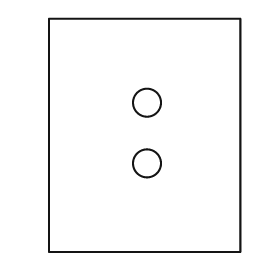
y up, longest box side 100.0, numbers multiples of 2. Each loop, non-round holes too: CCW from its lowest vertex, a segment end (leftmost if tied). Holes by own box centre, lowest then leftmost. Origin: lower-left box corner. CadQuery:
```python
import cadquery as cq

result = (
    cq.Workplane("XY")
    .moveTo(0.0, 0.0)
    .lineTo(82.0, 0.0)
    .lineTo(82.0, 100.0)
    .lineTo(0.0, 100.0)
    .close()
    .moveTo(42.0, 38.0)
    .circle(6.0)
    .moveTo(42.0, 64.0)
    .circle(6.0)
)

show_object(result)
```